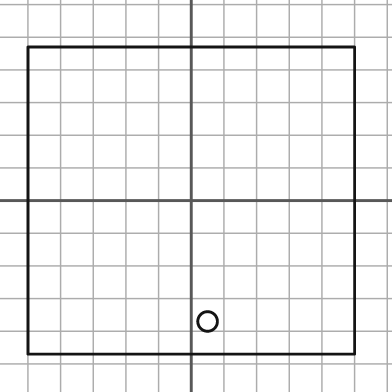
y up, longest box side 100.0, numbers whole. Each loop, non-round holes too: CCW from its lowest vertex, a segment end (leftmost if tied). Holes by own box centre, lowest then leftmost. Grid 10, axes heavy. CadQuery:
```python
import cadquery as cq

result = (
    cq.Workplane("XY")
    .moveTo(-50.0, -47.0)
    .lineTo(50.0, -47.0)
    .lineTo(50.0, 47.0)
    .lineTo(-50.0, 47.0)
    .close()
    .moveTo(5.0, -37.0)
    .circle(3.0)
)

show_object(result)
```